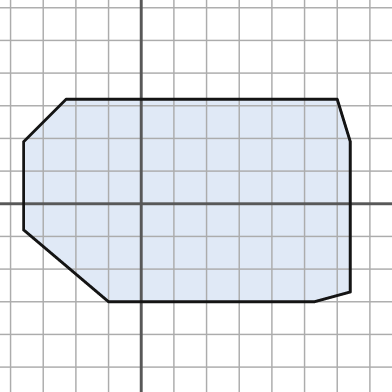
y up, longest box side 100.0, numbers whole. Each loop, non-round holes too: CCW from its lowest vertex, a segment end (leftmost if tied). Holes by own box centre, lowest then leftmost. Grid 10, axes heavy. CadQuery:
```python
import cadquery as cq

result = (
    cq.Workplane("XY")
    .moveTo(-10.0, -30.0)
    .lineTo(53.0, -30.0)
    .lineTo(64.0, -27.0)
    .lineTo(64.0, 19.0)
    .lineTo(60.0, 32.0)
    .lineTo(-23.0, 32.0)
    .lineTo(-36.0, 19.0)
    .lineTo(-36.0, -8.0)
    .close()
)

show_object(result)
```